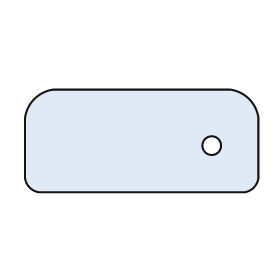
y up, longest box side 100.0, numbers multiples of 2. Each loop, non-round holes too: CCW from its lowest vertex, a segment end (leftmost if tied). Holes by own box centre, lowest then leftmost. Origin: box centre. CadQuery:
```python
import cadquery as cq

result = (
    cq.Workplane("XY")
    .moveTo(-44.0, -22.0)
    .lineTo(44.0, -22.0)
    .threePointArc((48.0, -20.0), (50.0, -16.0))
    .lineTo(50.0, 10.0)
    .threePointArc((46.0, 18.0), (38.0, 22.0))
    .lineTo(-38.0, 22.0)
    .threePointArc((-46.0, 18.0), (-50.0, 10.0))
    .lineTo(-50.0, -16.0)
    .threePointArc((-48.0, -20.0), (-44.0, -22.0))
    .close()
    .moveTo(30.0, -2.0)
    .circle(4.0)
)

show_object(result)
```